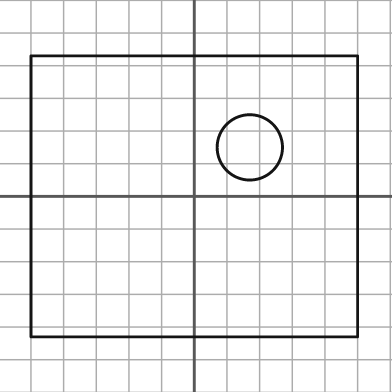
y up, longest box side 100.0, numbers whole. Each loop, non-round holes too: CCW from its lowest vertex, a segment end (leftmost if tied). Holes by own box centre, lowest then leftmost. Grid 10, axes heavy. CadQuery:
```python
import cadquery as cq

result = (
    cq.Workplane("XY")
    .moveTo(-50.0, -43.0)
    .lineTo(50.0, -43.0)
    .lineTo(50.0, 43.0)
    .lineTo(-50.0, 43.0)
    .close()
    .moveTo(17.0, 15.0)
    .circle(10.0)
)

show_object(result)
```